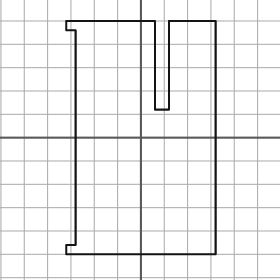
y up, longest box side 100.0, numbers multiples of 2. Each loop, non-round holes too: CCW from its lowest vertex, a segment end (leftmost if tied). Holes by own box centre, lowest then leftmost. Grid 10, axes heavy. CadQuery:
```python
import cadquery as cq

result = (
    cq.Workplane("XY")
    .moveTo(-32.0, -50.0)
    .lineTo(32.0, -50.0)
    .lineTo(32.0, 50.0)
    .lineTo(12.0, 50.0)
    .lineTo(12.0, 12.0)
    .lineTo(6.0, 12.0)
    .lineTo(6.0, 50.0)
    .lineTo(-32.0, 50.0)
    .lineTo(-32.0, 46.0)
    .lineTo(-28.0, 46.0)
    .lineTo(-28.0, -46.0)
    .lineTo(-32.0, -46.0)
    .close()
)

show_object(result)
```